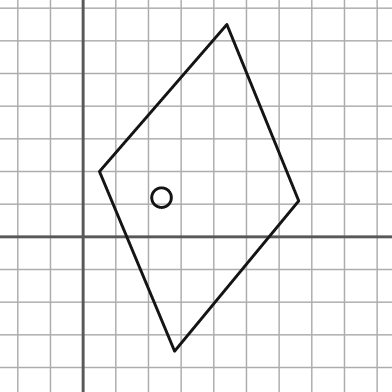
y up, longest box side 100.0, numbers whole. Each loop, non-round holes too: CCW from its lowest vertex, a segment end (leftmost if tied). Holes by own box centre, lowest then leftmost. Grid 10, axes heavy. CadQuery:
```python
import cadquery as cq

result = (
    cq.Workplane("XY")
    .moveTo(28.0, -35.0)
    .lineTo(66.0, 11.0)
    .lineTo(44.0, 65.0)
    .lineTo(5.0, 20.0)
    .close()
    .moveTo(24.0, 12.0)
    .circle(3.0)
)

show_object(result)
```